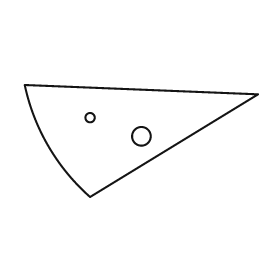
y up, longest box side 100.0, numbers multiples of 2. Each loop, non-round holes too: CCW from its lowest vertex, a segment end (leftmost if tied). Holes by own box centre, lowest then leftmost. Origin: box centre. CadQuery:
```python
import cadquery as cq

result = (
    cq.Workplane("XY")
    .moveTo(-22.0, -24.0)
    .lineTo(50.0, 20.0)
    .lineTo(-50.0, 24.0)
    .threePointArc((-40.0, -2.0), (-22.0, -24.0))
    .close()
    .moveTo(0.0, 2.0)
    .circle(4.0)
    .moveTo(-22.0, 10.0)
    .circle(2.0)
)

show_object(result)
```